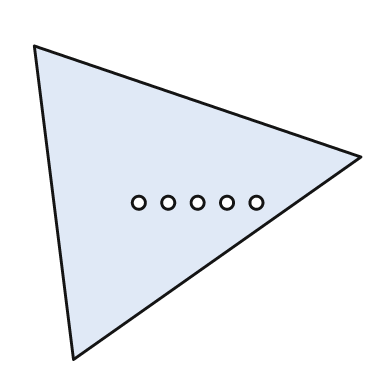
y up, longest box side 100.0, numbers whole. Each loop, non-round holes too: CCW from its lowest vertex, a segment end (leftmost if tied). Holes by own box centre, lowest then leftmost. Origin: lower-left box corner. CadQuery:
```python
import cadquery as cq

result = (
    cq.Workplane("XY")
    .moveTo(12.0, 0.0)
    .lineTo(100.0, 62.0)
    .lineTo(0.0, 96.0)
    .close()
    .moveTo(32.0, 48.0)
    .circle(2.0)
    .moveTo(41.0, 48.0)
    .circle(2.0)
    .moveTo(50.0, 48.0)
    .circle(2.0)
    .moveTo(59.0, 48.0)
    .circle(2.0)
    .moveTo(68.0, 48.0)
    .circle(2.0)
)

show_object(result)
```